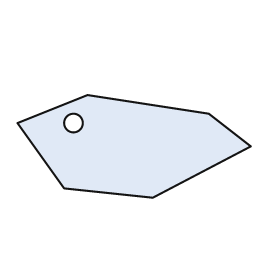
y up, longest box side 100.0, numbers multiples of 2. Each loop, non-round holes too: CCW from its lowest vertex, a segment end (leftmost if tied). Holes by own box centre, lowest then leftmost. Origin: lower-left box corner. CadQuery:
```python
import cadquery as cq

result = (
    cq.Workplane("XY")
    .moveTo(58.0, 0.0)
    .lineTo(100.0, 22.0)
    .lineTo(82.0, 36.0)
    .lineTo(30.0, 44.0)
    .lineTo(0.0, 32.0)
    .lineTo(20.0, 4.0)
    .close()
    .moveTo(24.0, 32.0)
    .circle(4.0)
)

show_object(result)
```